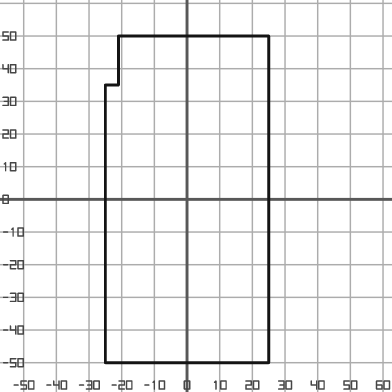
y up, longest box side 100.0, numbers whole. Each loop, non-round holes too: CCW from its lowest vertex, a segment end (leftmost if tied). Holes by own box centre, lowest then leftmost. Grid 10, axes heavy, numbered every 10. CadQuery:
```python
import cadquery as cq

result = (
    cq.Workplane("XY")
    .moveTo(-25.0, -50.0)
    .lineTo(25.0, -50.0)
    .lineTo(25.0, 50.0)
    .lineTo(-21.0, 50.0)
    .lineTo(-21.0, 35.0)
    .lineTo(-25.0, 35.0)
    .close()
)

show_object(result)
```